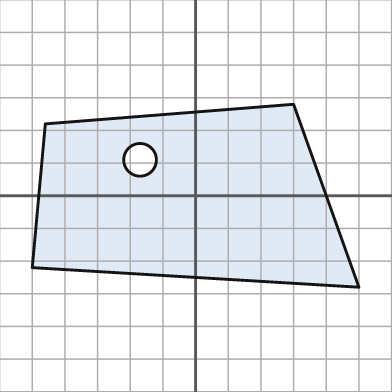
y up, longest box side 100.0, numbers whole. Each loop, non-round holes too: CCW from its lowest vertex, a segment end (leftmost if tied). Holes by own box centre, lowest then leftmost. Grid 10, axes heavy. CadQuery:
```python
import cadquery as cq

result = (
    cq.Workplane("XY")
    .moveTo(50.0, -28.0)
    .lineTo(30.0, 28.0)
    .lineTo(-46.0, 22.0)
    .lineTo(-50.0, -22.0)
    .close()
    .moveTo(-17.0, 11.0)
    .circle(5.0)
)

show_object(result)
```